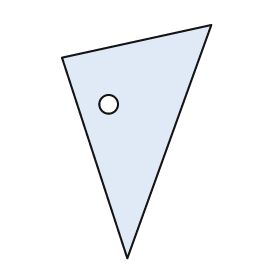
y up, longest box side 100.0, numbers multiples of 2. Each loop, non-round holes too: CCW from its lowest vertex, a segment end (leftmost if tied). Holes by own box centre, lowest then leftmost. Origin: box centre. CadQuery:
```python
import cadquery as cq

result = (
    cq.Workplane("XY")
    .moveTo(-4.0, -50.0)
    .lineTo(32.0, 50.0)
    .lineTo(-32.0, 36.0)
    .close()
    .moveTo(-12.0, 16.0)
    .circle(4.0)
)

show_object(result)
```